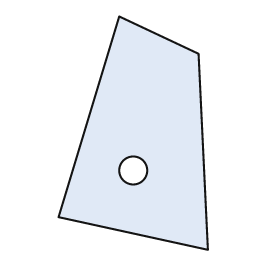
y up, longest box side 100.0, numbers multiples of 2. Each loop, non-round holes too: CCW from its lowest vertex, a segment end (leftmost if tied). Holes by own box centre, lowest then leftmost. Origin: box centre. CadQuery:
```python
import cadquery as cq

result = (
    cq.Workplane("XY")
    .moveTo(32.0, -50.0)
    .lineTo(28.0, 34.0)
    .lineTo(-6.0, 50.0)
    .lineTo(-32.0, -36.0)
    .close()
    .moveTo(0.0, -16.0)
    .circle(6.0)
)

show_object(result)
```